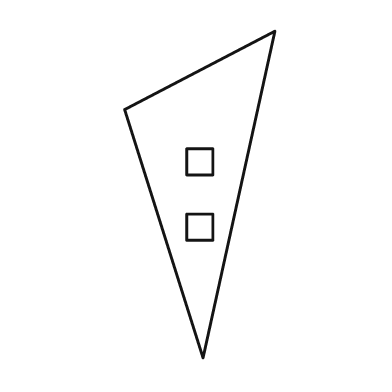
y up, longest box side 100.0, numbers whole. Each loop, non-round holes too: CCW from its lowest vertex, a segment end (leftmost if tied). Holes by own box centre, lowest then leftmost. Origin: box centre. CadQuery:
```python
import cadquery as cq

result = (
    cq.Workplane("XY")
    .moveTo(1.0, -50.0)
    .lineTo(23.0, 50.0)
    .lineTo(-23.0, 26.0)
    .close()
    .moveTo(-4.0, -14.0)
    .lineTo(4.0, -14.0)
    .lineTo(4.0, -6.0)
    .lineTo(-4.0, -6.0)
    .close()
    .moveTo(-4.0, 6.0)
    .lineTo(4.0, 6.0)
    .lineTo(4.0, 14.0)
    .lineTo(-4.0, 14.0)
    .close()
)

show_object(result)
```